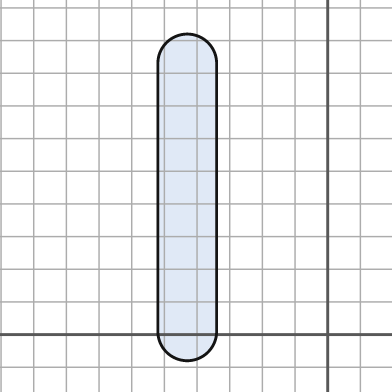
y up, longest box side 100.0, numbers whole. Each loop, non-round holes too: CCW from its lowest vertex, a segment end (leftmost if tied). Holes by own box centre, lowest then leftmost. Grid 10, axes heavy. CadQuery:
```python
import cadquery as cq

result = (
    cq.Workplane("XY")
    .moveTo(-52.0, 1.0)
    .threePointArc((-43.0, -8.0), (-34.0, 1.0))
    .lineTo(-34.0, 83.0)
    .threePointArc((-43.0, 92.0), (-52.0, 83.0))
    .close()
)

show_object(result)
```